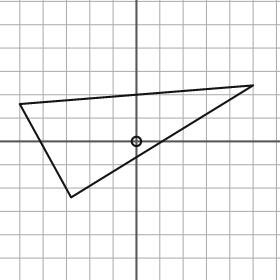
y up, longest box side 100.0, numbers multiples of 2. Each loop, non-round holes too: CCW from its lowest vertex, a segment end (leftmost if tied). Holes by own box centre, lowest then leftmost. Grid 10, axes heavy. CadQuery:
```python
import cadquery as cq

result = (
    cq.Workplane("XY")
    .moveTo(-28.0, -24.0)
    .lineTo(50.0, 24.0)
    .lineTo(-50.0, 16.0)
    .close()
    .moveTo(0.0, 0.0)
    .circle(2.0)
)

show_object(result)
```